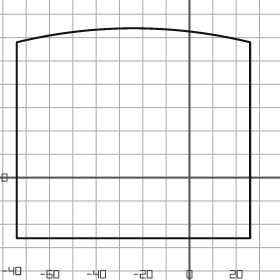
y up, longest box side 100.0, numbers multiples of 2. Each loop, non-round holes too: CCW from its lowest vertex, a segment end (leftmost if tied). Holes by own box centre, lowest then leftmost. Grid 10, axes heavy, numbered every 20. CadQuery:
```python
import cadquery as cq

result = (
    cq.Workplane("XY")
    .moveTo(-74.0, -26.0)
    .lineTo(26.0, -26.0)
    .lineTo(26.0, 58.0)
    .threePointArc((-24.0, 64.0), (-74.0, 58.0))
    .close()
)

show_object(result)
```